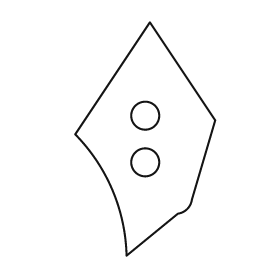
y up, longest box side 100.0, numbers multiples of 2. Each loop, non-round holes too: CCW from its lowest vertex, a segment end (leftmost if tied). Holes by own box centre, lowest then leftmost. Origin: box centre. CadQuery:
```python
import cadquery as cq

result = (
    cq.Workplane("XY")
    .moveTo(-8.0, -50.0)
    .lineTo(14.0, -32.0)
    .threePointArc((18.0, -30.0), (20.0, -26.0))
    .lineTo(30.0, 8.0)
    .lineTo(2.0, 50.0)
    .lineTo(-30.0, 2.0)
    .threePointArc((-14.0, -22.0), (-8.0, -50.0))
    .close()
    .moveTo(0.0, -10.0)
    .circle(6.0)
    .moveTo(0.0, 10.0)
    .circle(6.0)
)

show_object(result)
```